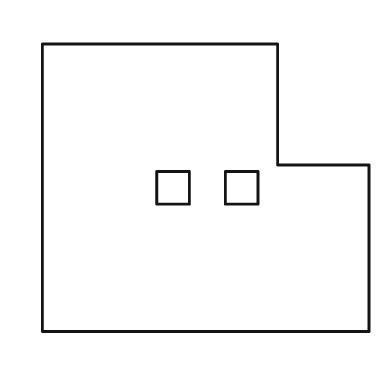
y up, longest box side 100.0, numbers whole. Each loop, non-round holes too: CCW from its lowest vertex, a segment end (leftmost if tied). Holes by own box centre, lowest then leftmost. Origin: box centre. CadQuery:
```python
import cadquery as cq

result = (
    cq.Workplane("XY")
    .moveTo(-50.0, -44.0)
    .lineTo(50.0, -44.0)
    .lineTo(50.0, 7.0)
    .lineTo(22.0, 7.0)
    .lineTo(22.0, 44.0)
    .lineTo(-50.0, 44.0)
    .close()
    .moveTo(-15.0, -5.0)
    .lineTo(-5.0, -5.0)
    .lineTo(-5.0, 5.0)
    .lineTo(-15.0, 5.0)
    .close()
    .moveTo(6.0, -5.0)
    .lineTo(16.0, -5.0)
    .lineTo(16.0, 5.0)
    .lineTo(6.0, 5.0)
    .close()
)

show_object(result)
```